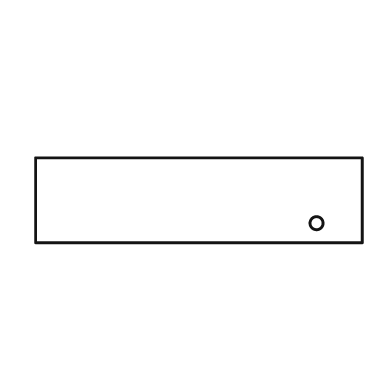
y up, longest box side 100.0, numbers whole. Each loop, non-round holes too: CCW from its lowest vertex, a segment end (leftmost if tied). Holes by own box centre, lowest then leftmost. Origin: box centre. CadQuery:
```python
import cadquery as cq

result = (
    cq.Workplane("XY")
    .moveTo(-50.0, -13.0)
    .lineTo(50.0, -13.0)
    .lineTo(50.0, 13.0)
    .lineTo(-50.0, 13.0)
    .close()
    .moveTo(36.0, -7.0)
    .circle(2.0)
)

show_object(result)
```